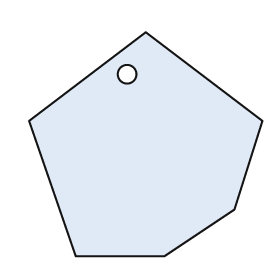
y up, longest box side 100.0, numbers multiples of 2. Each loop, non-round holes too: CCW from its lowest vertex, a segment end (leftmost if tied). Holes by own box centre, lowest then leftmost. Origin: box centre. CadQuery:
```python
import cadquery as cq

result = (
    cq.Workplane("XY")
    .moveTo(-30.0, -48.0)
    .lineTo(8.0, -48.0)
    .lineTo(38.0, -28.0)
    .lineTo(50.0, 10.0)
    .lineTo(0.0, 48.0)
    .lineTo(-50.0, 10.0)
    .close()
    .moveTo(-8.0, 30.0)
    .circle(4.0)
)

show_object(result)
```